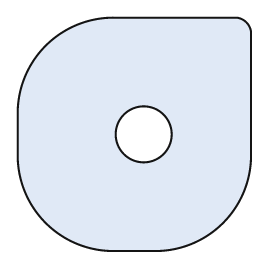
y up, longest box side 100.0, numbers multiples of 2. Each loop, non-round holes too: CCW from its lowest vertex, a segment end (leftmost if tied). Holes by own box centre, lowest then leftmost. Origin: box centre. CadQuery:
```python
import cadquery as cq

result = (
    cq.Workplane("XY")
    .moveTo(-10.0, -50.0)
    .lineTo(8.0, -50.0)
    .threePointArc((38.0, -38.0), (50.0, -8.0))
    .lineTo(50.0, 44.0)
    .threePointArc((48.0, 48.0), (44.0, 50.0))
    .lineTo(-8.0, 50.0)
    .threePointArc((-38.0, 38.0), (-50.0, 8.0))
    .lineTo(-50.0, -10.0)
    .threePointArc((-38.0, -38.0), (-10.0, -50.0))
    .close()
    .moveTo(4.0, 0.0)
    .circle(12.0)
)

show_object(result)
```